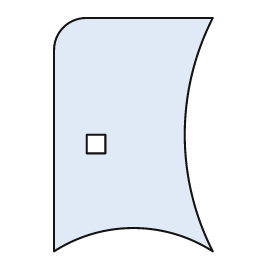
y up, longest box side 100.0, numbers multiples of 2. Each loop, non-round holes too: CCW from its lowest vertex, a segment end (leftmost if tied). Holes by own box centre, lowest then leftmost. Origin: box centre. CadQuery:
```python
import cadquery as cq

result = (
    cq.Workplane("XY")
    .moveTo(-34.0, -50.0)
    .threePointArc((0.0, -40.0), (34.0, -50.0))
    .threePointArc((22.0, 0.0), (34.0, 50.0))
    .lineTo(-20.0, 50.0)
    .threePointArc((-30.0, 46.0), (-34.0, 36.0))
    .close()
    .moveTo(-20.0, -8.0)
    .lineTo(-12.0, -8.0)
    .lineTo(-12.0, 0.0)
    .lineTo(-20.0, 0.0)
    .close()
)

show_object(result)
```